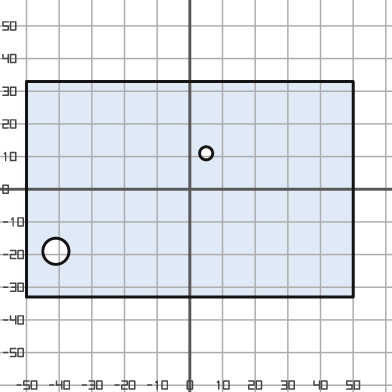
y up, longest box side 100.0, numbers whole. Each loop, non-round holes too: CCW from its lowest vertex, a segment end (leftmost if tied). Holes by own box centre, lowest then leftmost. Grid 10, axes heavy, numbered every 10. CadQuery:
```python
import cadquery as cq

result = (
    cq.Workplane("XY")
    .moveTo(-50.0, -33.0)
    .lineTo(50.0, -33.0)
    .lineTo(50.0, 33.0)
    .lineTo(-50.0, 33.0)
    .close()
    .moveTo(-41.0, -19.0)
    .circle(4.0)
    .moveTo(5.0, 11.0)
    .circle(2.0)
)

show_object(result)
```